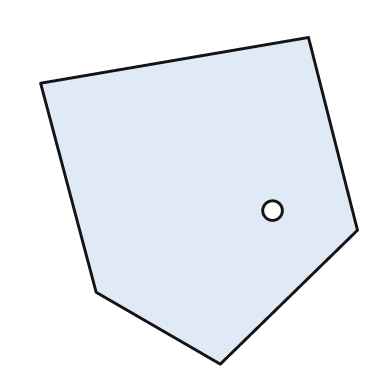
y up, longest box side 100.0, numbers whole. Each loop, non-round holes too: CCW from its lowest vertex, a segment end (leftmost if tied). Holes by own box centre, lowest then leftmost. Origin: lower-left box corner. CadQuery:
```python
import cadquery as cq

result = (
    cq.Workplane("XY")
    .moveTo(55.0, 0.0)
    .lineTo(97.0, 41.0)
    .lineTo(82.0, 100.0)
    .lineTo(0.0, 86.0)
    .lineTo(17.0, 22.0)
    .close()
    .moveTo(71.0, 47.0)
    .circle(3.0)
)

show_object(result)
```